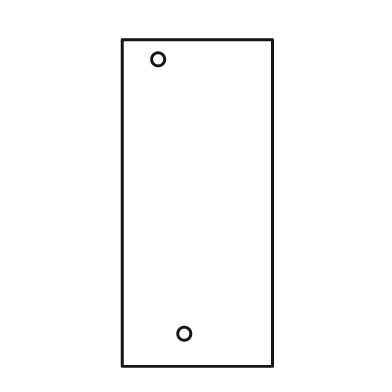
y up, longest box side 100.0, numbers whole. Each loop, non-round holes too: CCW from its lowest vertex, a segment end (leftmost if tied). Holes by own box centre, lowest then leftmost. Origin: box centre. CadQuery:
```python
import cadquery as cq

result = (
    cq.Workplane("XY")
    .moveTo(-23.0, -50.0)
    .lineTo(23.0, -50.0)
    .lineTo(23.0, 50.0)
    .lineTo(-23.0, 50.0)
    .close()
    .moveTo(-4.0, -40.0)
    .circle(2.0)
    .moveTo(-12.0, 44.0)
    .circle(2.0)
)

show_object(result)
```